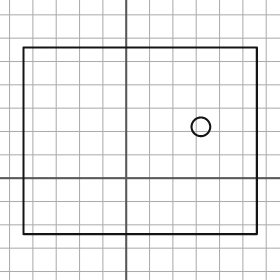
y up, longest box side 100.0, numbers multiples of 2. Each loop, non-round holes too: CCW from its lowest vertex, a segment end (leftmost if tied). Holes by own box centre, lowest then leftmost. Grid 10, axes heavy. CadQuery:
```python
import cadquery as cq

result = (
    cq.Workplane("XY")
    .moveTo(-44.0, -24.0)
    .lineTo(56.0, -24.0)
    .lineTo(56.0, 56.0)
    .lineTo(-44.0, 56.0)
    .close()
    .moveTo(32.0, 22.0)
    .circle(4.0)
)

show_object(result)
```